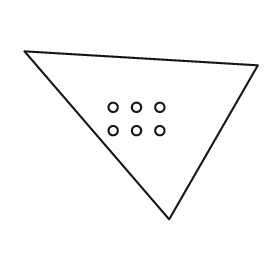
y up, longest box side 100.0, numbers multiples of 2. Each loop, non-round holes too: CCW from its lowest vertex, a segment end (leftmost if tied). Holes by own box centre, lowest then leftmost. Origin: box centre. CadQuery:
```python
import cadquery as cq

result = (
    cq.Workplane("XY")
    .moveTo(12.0, -36.0)
    .lineTo(50.0, 30.0)
    .lineTo(-50.0, 36.0)
    .close()
    .moveTo(-12.0, 2.0)
    .circle(2.0)
    .moveTo(-2.0, 2.0)
    .circle(2.0)
    .moveTo(8.0, 2.0)
    .circle(2.0)
    .moveTo(-12.0, 12.0)
    .circle(2.0)
    .moveTo(-2.0, 12.0)
    .circle(2.0)
    .moveTo(8.0, 12.0)
    .circle(2.0)
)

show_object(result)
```